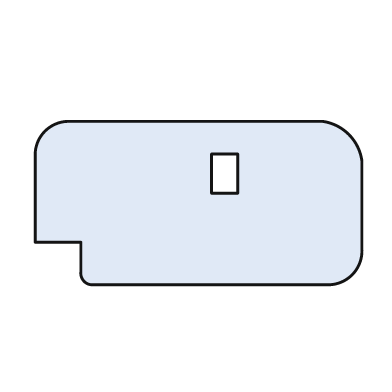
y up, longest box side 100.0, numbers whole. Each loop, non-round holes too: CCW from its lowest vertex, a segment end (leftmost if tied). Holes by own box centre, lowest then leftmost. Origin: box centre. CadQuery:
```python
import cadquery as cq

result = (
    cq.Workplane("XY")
    .moveTo(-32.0, -25.0)
    .lineTo(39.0, -25.0)
    .threePointArc((47.0, -22.0), (50.0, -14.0))
    .lineTo(50.0, 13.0)
    .threePointArc((46.0, 21.0), (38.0, 25.0))
    .lineTo(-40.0, 25.0)
    .threePointArc((-47.0, 22.0), (-50.0, 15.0))
    .lineTo(-50.0, -12.0)
    .lineTo(-36.0, -12.0)
    .lineTo(-36.0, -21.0)
    .threePointArc((-35.0, -24.0), (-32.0, -25.0))
    .close()
    .moveTo(4.0, 3.0)
    .lineTo(12.0, 3.0)
    .lineTo(12.0, 15.0)
    .lineTo(4.0, 15.0)
    .close()
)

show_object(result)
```